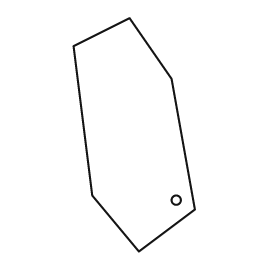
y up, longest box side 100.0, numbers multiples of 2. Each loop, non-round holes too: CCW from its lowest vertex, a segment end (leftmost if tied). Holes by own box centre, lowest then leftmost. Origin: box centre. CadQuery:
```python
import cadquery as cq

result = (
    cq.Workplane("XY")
    .moveTo(2.0, -50.0)
    .lineTo(26.0, -32.0)
    .lineTo(16.0, 24.0)
    .lineTo(-2.0, 50.0)
    .lineTo(-26.0, 38.0)
    .lineTo(-18.0, -26.0)
    .close()
    .moveTo(18.0, -28.0)
    .circle(2.0)
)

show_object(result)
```